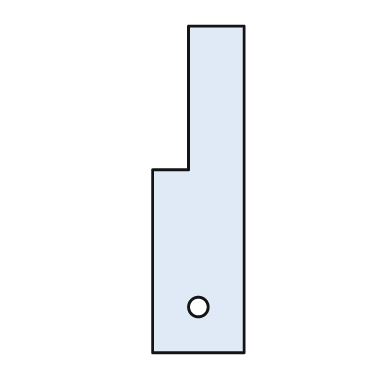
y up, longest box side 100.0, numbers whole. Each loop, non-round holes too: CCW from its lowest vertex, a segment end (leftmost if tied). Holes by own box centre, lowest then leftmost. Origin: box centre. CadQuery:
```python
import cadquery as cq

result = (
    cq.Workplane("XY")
    .moveTo(-14.0, -50.0)
    .lineTo(14.0, -50.0)
    .lineTo(14.0, 50.0)
    .lineTo(-3.0, 50.0)
    .lineTo(-3.0, 6.0)
    .lineTo(-14.0, 6.0)
    .close()
    .moveTo(0.0, -36.0)
    .circle(3.0)
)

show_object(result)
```